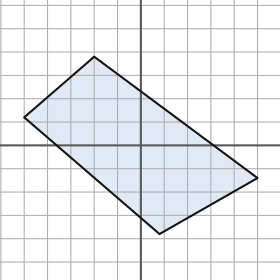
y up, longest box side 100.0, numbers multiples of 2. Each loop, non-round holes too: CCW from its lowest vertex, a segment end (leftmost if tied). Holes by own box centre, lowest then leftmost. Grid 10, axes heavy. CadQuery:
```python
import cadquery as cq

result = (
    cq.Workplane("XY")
    .moveTo(8.0, -38.0)
    .lineTo(50.0, -14.0)
    .lineTo(-20.0, 38.0)
    .lineTo(-50.0, 12.0)
    .close()
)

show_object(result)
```